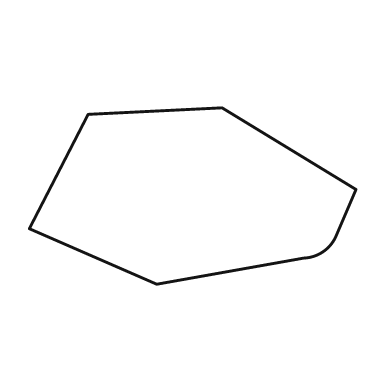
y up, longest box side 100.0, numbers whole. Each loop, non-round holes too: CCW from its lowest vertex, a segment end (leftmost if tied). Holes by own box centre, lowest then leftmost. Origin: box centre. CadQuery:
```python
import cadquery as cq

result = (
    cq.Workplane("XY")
    .moveTo(-11.0, -27.0)
    .lineTo(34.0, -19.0)
    .threePointArc((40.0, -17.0), (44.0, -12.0))
    .lineTo(50.0, 2.0)
    .lineTo(9.0, 27.0)
    .lineTo(-32.0, 25.0)
    .lineTo(-50.0, -10.0)
    .close()
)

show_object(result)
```